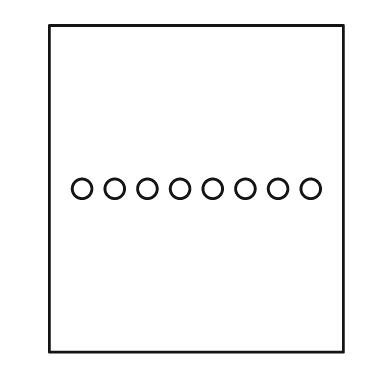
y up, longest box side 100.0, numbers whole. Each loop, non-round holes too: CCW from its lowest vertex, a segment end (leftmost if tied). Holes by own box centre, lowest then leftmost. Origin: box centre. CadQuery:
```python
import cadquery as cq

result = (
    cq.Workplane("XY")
    .moveTo(-45.0, -50.0)
    .lineTo(45.0, -50.0)
    .lineTo(45.0, 50.0)
    .lineTo(-45.0, 50.0)
    .close()
    .moveTo(-35.0, 0.0)
    .circle(3.0)
    .moveTo(-25.0, 0.0)
    .circle(3.0)
    .moveTo(-15.0, 0.0)
    .circle(3.0)
    .moveTo(-5.0, 0.0)
    .circle(3.0)
    .moveTo(5.0, 0.0)
    .circle(3.0)
    .moveTo(15.0, 0.0)
    .circle(3.0)
    .moveTo(25.0, 0.0)
    .circle(3.0)
    .moveTo(35.0, 0.0)
    .circle(3.0)
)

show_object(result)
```